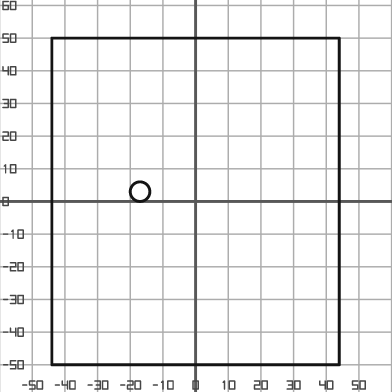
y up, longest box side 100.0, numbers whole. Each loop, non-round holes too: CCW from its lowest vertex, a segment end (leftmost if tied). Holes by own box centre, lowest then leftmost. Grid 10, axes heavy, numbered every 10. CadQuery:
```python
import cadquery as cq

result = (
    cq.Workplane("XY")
    .moveTo(-44.0, -50.0)
    .lineTo(44.0, -50.0)
    .lineTo(44.0, 50.0)
    .lineTo(-44.0, 50.0)
    .close()
    .moveTo(-17.0, 3.0)
    .circle(3.0)
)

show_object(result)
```